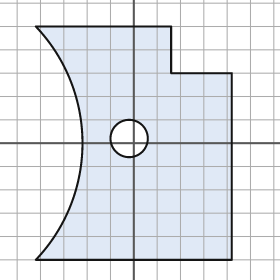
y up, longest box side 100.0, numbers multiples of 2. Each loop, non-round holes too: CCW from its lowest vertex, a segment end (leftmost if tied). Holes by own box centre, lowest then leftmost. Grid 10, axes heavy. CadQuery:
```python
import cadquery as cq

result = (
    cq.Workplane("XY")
    .moveTo(-42.0, -50.0)
    .lineTo(42.0, -50.0)
    .lineTo(42.0, 30.0)
    .lineTo(16.0, 30.0)
    .lineTo(16.0, 50.0)
    .lineTo(-42.0, 50.0)
    .threePointArc((-22.0, 0.0), (-42.0, -50.0))
    .close()
    .moveTo(-2.0, 2.0)
    .circle(8.0)
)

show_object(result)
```